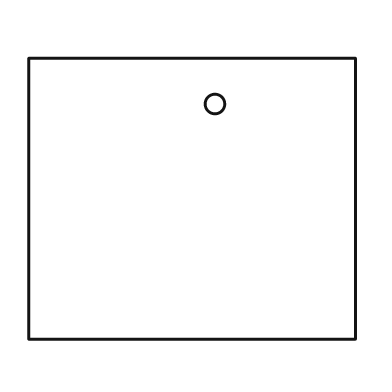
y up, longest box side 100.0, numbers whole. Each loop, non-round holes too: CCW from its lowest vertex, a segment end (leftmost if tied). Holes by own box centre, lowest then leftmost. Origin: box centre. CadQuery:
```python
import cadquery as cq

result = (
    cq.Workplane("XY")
    .moveTo(-50.0, -43.0)
    .lineTo(50.0, -43.0)
    .lineTo(50.0, 43.0)
    .lineTo(-50.0, 43.0)
    .close()
    .moveTo(7.0, 29.0)
    .circle(3.0)
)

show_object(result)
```